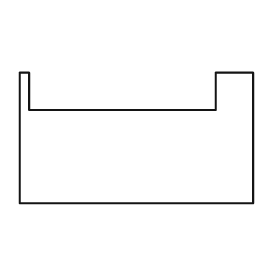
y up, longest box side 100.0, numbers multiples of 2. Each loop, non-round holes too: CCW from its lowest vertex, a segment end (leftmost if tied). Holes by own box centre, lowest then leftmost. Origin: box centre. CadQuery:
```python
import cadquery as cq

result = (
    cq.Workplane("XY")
    .moveTo(-50.0, -28.0)
    .lineTo(50.0, -28.0)
    .lineTo(50.0, 28.0)
    .lineTo(34.0, 28.0)
    .lineTo(34.0, 12.0)
    .lineTo(-46.0, 12.0)
    .lineTo(-46.0, 28.0)
    .lineTo(-50.0, 28.0)
    .close()
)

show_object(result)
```